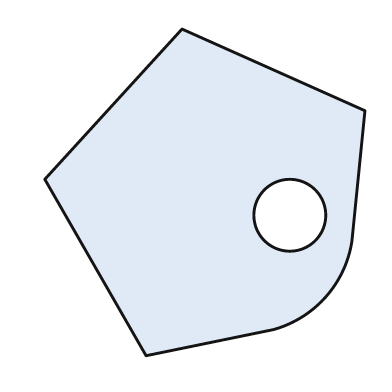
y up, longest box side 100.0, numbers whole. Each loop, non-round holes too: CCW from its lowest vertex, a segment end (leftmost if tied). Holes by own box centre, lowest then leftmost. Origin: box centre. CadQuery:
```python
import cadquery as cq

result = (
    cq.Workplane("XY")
    .moveTo(-18.0, -50.0)
    .lineTo(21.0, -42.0)
    .threePointArc((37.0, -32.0), (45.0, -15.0))
    .lineTo(49.0, 25.0)
    .lineTo(-7.0, 50.0)
    .lineTo(-49.0, 4.0)
    .close()
    .moveTo(26.0, -7.0)
    .circle(11.0)
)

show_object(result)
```